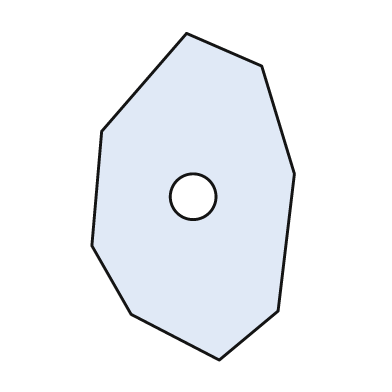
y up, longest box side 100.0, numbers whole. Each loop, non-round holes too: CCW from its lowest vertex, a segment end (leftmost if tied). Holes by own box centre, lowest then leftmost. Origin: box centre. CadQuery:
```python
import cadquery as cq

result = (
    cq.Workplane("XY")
    .moveTo(8.0, -50.0)
    .lineTo(26.0, -35.0)
    .lineTo(31.0, 7.0)
    .lineTo(21.0, 40.0)
    .lineTo(-2.0, 50.0)
    .lineTo(-28.0, 20.0)
    .lineTo(-31.0, -15.0)
    .lineTo(-19.0, -36.0)
    .close()
    .moveTo(0.0, 0.0)
    .circle(7.0)
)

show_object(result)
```